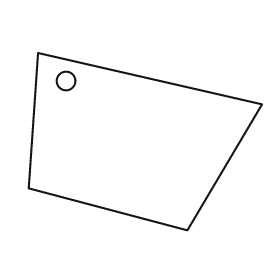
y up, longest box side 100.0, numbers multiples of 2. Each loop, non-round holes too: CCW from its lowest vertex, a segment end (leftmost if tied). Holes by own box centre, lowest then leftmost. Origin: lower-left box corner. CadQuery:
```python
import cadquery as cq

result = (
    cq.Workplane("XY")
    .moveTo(68.0, 0.0)
    .lineTo(100.0, 54.0)
    .lineTo(4.0, 76.0)
    .lineTo(0.0, 18.0)
    .close()
    .moveTo(16.0, 64.0)
    .circle(4.0)
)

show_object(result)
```